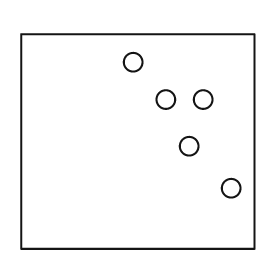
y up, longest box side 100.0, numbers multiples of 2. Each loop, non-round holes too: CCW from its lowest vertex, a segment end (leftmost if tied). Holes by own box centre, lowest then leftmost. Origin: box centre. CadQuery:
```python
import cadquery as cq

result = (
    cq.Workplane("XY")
    .moveTo(-50.0, -46.0)
    .lineTo(50.0, -46.0)
    .lineTo(50.0, 46.0)
    .lineTo(-50.0, 46.0)
    .close()
    .moveTo(40.0, -20.0)
    .circle(4.0)
    .moveTo(22.0, -2.0)
    .circle(4.0)
    .moveTo(12.0, 18.0)
    .circle(4.0)
    .moveTo(28.0, 18.0)
    .circle(4.0)
    .moveTo(-2.0, 34.0)
    .circle(4.0)
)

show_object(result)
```